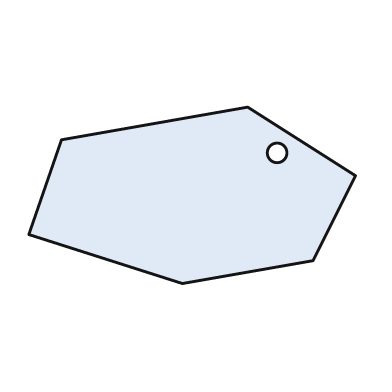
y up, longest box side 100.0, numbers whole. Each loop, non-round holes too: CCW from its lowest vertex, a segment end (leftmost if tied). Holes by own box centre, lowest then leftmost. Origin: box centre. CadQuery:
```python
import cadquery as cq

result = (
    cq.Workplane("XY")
    .moveTo(-3.0, -27.0)
    .lineTo(37.0, -20.0)
    .lineTo(50.0, 6.0)
    .lineTo(17.0, 27.0)
    .lineTo(-40.0, 17.0)
    .lineTo(-50.0, -12.0)
    .close()
    .moveTo(26.0, 13.0)
    .circle(3.0)
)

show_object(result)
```